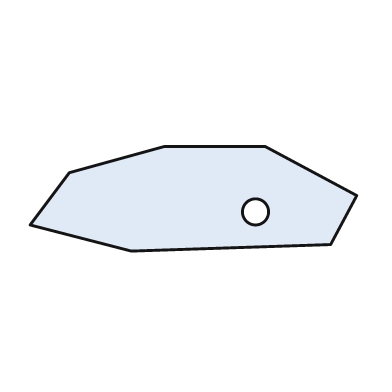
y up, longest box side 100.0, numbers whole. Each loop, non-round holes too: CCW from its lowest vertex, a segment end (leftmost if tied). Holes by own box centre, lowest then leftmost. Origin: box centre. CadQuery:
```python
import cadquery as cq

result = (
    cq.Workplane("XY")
    .moveTo(-19.0, -16.0)
    .lineTo(42.0, -14.0)
    .lineTo(50.0, 1.0)
    .lineTo(22.0, 16.0)
    .lineTo(-9.0, 16.0)
    .lineTo(-38.0, 8.0)
    .lineTo(-50.0, -8.0)
    .close()
    .moveTo(19.0, -4.0)
    .circle(4.0)
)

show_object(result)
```